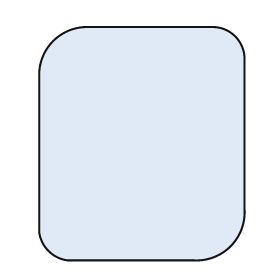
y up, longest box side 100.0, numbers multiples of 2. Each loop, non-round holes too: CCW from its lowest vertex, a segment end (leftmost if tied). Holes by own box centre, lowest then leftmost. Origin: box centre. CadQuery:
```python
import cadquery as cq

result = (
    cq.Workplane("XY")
    .moveTo(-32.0, -50.0)
    .lineTo(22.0, -50.0)
    .threePointArc((38.0, -44.0), (44.0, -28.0))
    .lineTo(44.0, 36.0)
    .threePointArc((40.0, 46.0), (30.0, 50.0))
    .lineTo(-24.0, 50.0)
    .threePointArc((-38.0, 44.0), (-44.0, 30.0))
    .lineTo(-44.0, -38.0)
    .threePointArc((-40.0, -46.0), (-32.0, -50.0))
    .close()
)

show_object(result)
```